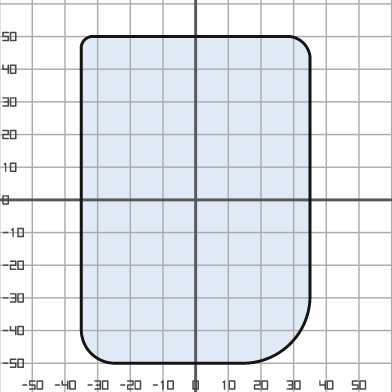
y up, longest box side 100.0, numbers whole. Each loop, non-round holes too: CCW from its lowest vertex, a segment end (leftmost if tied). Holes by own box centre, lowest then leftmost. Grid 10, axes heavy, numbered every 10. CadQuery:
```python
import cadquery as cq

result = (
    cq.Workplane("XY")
    .moveTo(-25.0, -50.0)
    .lineTo(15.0, -50.0)
    .threePointArc((29.0, -44.0), (35.0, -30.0))
    .lineTo(35.0, 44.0)
    .threePointArc((33.0, 48.0), (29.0, 50.0))
    .lineTo(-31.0, 50.0)
    .threePointArc((-34.0, 49.0), (-35.0, 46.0))
    .lineTo(-35.0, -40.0)
    .threePointArc((-32.0, -47.0), (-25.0, -50.0))
    .close()
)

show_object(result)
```